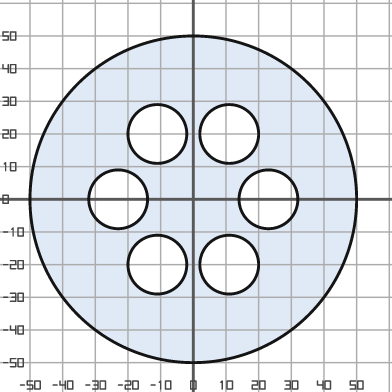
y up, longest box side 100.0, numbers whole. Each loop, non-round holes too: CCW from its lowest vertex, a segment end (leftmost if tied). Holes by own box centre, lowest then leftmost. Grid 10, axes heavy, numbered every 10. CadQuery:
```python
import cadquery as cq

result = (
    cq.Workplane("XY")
    .moveTo(0.0, 0.0)
    .circle(50.0)
    .moveTo(-11.0, -20.0)
    .circle(9.0)
    .moveTo(11.0, -20.0)
    .circle(9.0)
    .moveTo(-23.0, 0.0)
    .circle(9.0)
    .moveTo(23.0, 0.0)
    .circle(9.0)
    .moveTo(-11.0, 20.0)
    .circle(9.0)
    .moveTo(11.0, 20.0)
    .circle(9.0)
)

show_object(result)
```